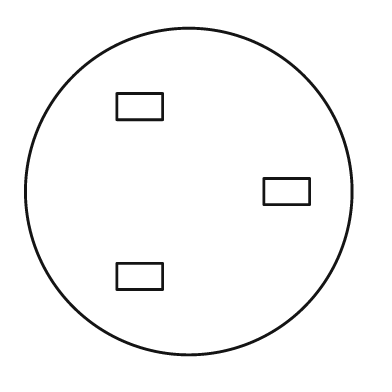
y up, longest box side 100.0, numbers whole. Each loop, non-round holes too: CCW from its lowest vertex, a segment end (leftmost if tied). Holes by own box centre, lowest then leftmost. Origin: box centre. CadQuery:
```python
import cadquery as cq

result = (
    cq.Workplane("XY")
    .moveTo(0.0, 0.0)
    .circle(50.0)
    .moveTo(-22.0, -30.0)
    .lineTo(-8.0, -30.0)
    .lineTo(-8.0, -22.0)
    .lineTo(-22.0, -22.0)
    .close()
    .moveTo(23.0, -4.0)
    .lineTo(37.0, -4.0)
    .lineTo(37.0, 4.0)
    .lineTo(23.0, 4.0)
    .close()
    .moveTo(-22.0, 22.0)
    .lineTo(-8.0, 22.0)
    .lineTo(-8.0, 30.0)
    .lineTo(-22.0, 30.0)
    .close()
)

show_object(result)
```